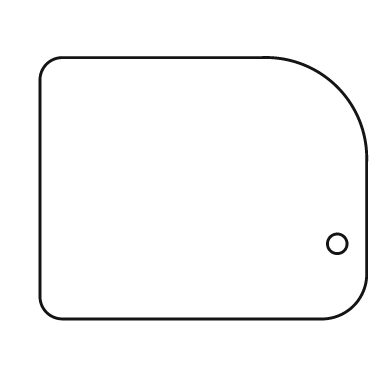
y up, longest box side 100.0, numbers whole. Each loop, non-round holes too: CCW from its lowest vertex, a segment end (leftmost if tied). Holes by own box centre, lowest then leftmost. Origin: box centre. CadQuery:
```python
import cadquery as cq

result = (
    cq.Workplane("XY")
    .moveTo(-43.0, -40.0)
    .lineTo(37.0, -40.0)
    .threePointArc((46.0, -36.0), (50.0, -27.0))
    .lineTo(50.0, 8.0)
    .threePointArc((41.0, 31.0), (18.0, 40.0))
    .lineTo(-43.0, 40.0)
    .threePointArc((-48.0, 38.0), (-50.0, 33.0))
    .lineTo(-50.0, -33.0)
    .threePointArc((-48.0, -38.0), (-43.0, -40.0))
    .close()
    .moveTo(41.0, -17.0)
    .circle(3.0)
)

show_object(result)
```